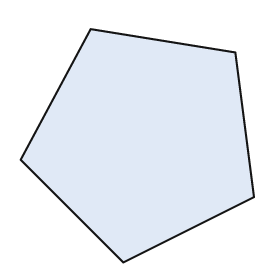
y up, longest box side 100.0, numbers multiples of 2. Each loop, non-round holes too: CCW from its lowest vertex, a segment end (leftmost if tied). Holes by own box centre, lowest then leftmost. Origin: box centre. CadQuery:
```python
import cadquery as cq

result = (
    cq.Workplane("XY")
    .moveTo(-6.0, -50.0)
    .lineTo(50.0, -22.0)
    .lineTo(42.0, 40.0)
    .lineTo(-20.0, 50.0)
    .lineTo(-50.0, -6.0)
    .close()
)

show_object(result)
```